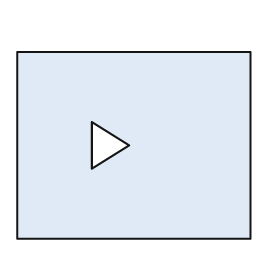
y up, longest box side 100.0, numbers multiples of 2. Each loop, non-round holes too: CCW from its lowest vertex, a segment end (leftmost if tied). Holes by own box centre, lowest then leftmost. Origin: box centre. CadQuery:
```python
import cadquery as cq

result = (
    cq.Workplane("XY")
    .moveTo(-50.0, -40.0)
    .lineTo(50.0, -40.0)
    .lineTo(50.0, 40.0)
    .lineTo(-50.0, 40.0)
    .close()
    .moveTo(-18.0, -10.0)
    .lineTo(-2.0, 0.0)
    .lineTo(-18.0, 10.0)
    .close()
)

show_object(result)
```